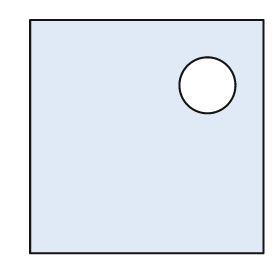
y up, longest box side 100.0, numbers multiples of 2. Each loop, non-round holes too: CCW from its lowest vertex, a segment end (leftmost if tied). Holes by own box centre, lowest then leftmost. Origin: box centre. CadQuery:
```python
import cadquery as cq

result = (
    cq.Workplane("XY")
    .moveTo(-50.0, -50.0)
    .lineTo(50.0, -50.0)
    .lineTo(50.0, 50.0)
    .lineTo(-50.0, 50.0)
    .close()
    .moveTo(26.0, 22.0)
    .circle(12.0)
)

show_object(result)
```